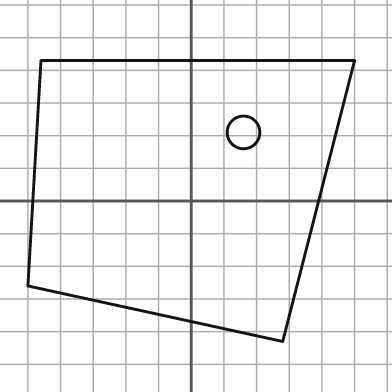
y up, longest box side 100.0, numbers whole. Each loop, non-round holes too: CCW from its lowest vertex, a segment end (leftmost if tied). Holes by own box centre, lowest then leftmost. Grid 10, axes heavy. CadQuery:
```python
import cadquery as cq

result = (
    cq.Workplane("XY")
    .moveTo(28.0, -43.0)
    .lineTo(50.0, 43.0)
    .lineTo(-46.0, 43.0)
    .lineTo(-50.0, -26.0)
    .close()
    .moveTo(16.0, 21.0)
    .circle(5.0)
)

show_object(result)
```